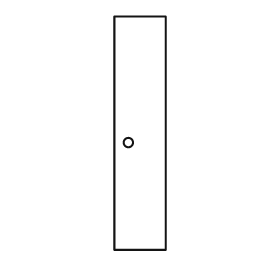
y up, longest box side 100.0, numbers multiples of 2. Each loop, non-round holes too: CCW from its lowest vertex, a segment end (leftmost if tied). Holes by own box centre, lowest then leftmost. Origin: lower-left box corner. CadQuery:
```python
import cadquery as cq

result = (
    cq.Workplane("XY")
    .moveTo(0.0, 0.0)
    .lineTo(22.0, 0.0)
    .lineTo(22.0, 100.0)
    .lineTo(0.0, 100.0)
    .close()
    .moveTo(6.0, 46.0)
    .circle(2.0)
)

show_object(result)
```